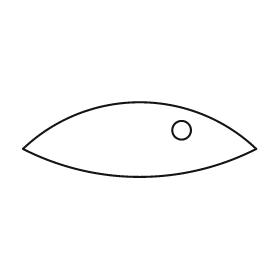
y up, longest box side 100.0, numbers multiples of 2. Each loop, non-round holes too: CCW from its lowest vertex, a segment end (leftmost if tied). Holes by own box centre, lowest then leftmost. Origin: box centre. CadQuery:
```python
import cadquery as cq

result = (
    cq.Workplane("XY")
    .moveTo(-50.0, -4.0)
    .threePointArc((0.0, -16.0), (50.0, -4.0))
    .threePointArc((0.0, 16.0), (-50.0, -4.0))
    .close()
    .moveTo(18.0, 4.0)
    .circle(4.0)
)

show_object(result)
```